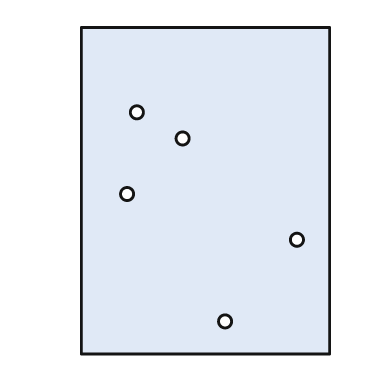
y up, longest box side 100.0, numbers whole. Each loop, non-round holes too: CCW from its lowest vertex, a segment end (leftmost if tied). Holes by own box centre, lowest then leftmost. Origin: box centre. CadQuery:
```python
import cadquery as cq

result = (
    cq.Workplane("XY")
    .moveTo(-38.0, -50.0)
    .lineTo(38.0, -50.0)
    .lineTo(38.0, 50.0)
    .lineTo(-38.0, 50.0)
    .close()
    .moveTo(6.0, -40.0)
    .circle(2.0)
    .moveTo(28.0, -15.0)
    .circle(2.0)
    .moveTo(-24.0, -1.0)
    .circle(2.0)
    .moveTo(-7.0, 16.0)
    .circle(2.0)
    .moveTo(-21.0, 24.0)
    .circle(2.0)
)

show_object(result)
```